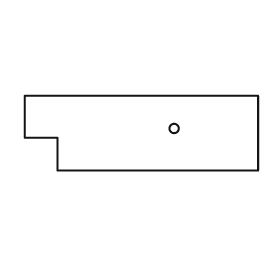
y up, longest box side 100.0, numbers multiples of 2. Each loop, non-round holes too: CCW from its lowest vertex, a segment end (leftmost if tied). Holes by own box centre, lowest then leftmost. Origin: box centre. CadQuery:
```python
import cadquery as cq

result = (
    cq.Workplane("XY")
    .moveTo(-36.0, -16.0)
    .lineTo(50.0, -16.0)
    .lineTo(50.0, 16.0)
    .lineTo(-50.0, 16.0)
    .lineTo(-50.0, -2.0)
    .lineTo(-36.0, -2.0)
    .close()
    .moveTo(14.0, 2.0)
    .circle(2.0)
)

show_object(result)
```